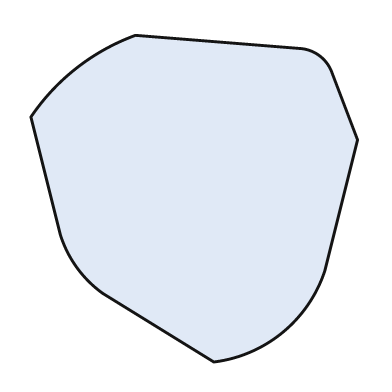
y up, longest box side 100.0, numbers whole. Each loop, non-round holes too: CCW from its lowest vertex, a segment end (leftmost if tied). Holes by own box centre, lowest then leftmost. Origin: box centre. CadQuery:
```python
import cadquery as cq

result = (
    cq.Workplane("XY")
    .moveTo(6.0, -50.0)
    .threePointArc((27.0, -41.0), (40.0, -22.0))
    .lineTo(50.0, 18.0)
    .lineTo(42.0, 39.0)
    .threePointArc((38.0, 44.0), (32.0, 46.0))
    .lineTo(-18.0, 50.0)
    .threePointArc((-36.0, 40.0), (-50.0, 25.0))
    .lineTo(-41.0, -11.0)
    .threePointArc((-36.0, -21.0), (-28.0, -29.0))
    .close()
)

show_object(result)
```